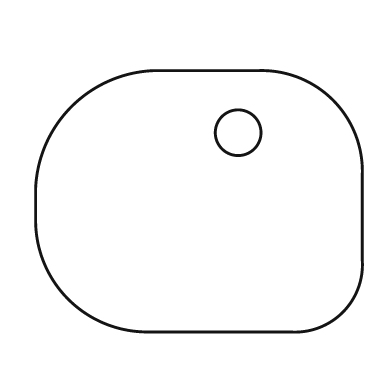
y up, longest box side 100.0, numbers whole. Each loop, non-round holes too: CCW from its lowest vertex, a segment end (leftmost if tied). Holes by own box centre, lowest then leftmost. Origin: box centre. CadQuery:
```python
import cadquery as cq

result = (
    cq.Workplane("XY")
    .moveTo(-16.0, -40.0)
    .lineTo(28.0, -40.0)
    .threePointArc((44.0, -34.0), (50.0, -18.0))
    .lineTo(50.0, 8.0)
    .threePointArc((41.0, 31.0), (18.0, 40.0))
    .lineTo(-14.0, 40.0)
    .threePointArc((-39.0, 29.0), (-50.0, 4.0))
    .lineTo(-50.0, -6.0)
    .threePointArc((-40.0, -30.0), (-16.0, -40.0))
    .close()
    .moveTo(12.0, 21.0)
    .circle(7.0)
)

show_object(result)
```